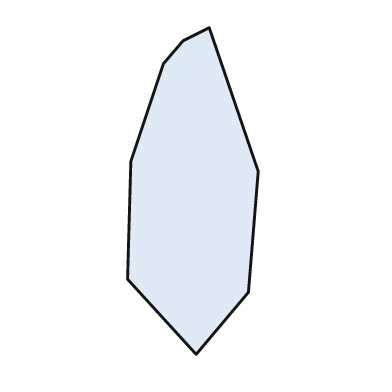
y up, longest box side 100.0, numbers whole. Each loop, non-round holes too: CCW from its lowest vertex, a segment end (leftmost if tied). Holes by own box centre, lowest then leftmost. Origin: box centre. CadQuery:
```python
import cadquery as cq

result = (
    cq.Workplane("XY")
    .moveTo(1.0, -50.0)
    .lineTo(17.0, -31.0)
    .lineTo(20.0, 6.0)
    .lineTo(5.0, 50.0)
    .lineTo(-3.0, 46.0)
    .lineTo(-9.0, 39.0)
    .lineTo(-19.0, 9.0)
    .lineTo(-20.0, -27.0)
    .close()
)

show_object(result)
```